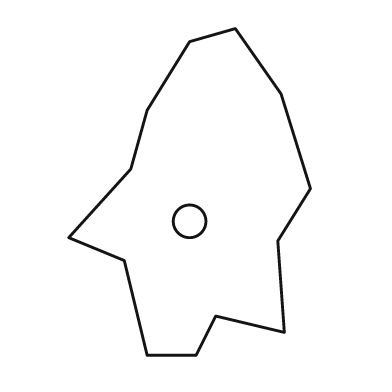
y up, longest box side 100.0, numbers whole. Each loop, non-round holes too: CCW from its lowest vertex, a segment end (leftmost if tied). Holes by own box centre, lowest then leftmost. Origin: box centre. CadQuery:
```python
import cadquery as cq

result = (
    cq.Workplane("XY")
    .moveTo(-13.0, -50.0)
    .lineTo(2.0, -50.0)
    .lineTo(8.0, -38.0)
    .lineTo(29.0, -43.0)
    .lineTo(27.0, -15.0)
    .lineTo(37.0, 1.0)
    .lineTo(28.0, 30.0)
    .lineTo(14.0, 50.0)
    .lineTo(0.0, 46.0)
    .lineTo(-13.0, 25.0)
    .lineTo(-18.0, 7.0)
    .lineTo(-37.0, -14.0)
    .lineTo(-20.0, -21.0)
    .close()
    .moveTo(0.0, -9.0)
    .circle(5.0)
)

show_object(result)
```